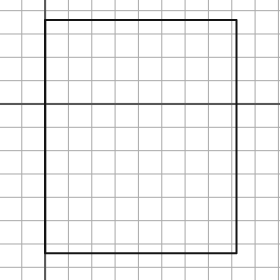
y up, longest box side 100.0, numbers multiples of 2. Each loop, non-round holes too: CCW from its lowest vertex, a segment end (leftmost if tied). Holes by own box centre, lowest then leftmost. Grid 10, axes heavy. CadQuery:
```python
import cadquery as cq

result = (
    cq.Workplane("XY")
    .moveTo(0.0, -64.0)
    .lineTo(82.0, -64.0)
    .lineTo(82.0, 36.0)
    .lineTo(0.0, 36.0)
    .close()
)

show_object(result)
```